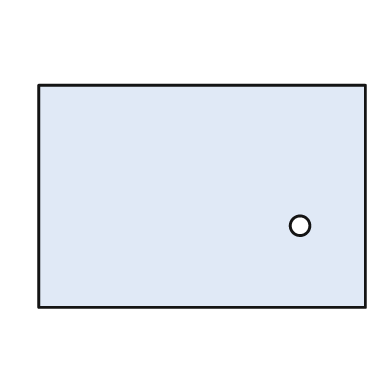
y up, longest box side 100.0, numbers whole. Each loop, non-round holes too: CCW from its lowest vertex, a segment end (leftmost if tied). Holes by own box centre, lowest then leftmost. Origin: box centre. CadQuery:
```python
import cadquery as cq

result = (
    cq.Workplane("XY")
    .moveTo(-50.0, -34.0)
    .lineTo(50.0, -34.0)
    .lineTo(50.0, 34.0)
    .lineTo(-50.0, 34.0)
    .close()
    .moveTo(30.0, -9.0)
    .circle(3.0)
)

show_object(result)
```